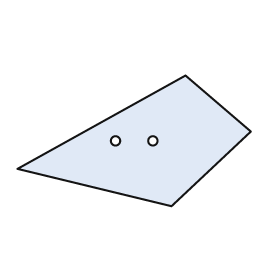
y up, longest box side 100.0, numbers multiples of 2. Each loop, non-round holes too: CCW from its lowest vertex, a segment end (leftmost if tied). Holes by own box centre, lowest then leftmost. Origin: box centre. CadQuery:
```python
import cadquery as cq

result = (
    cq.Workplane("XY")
    .moveTo(16.0, -28.0)
    .lineTo(50.0, 4.0)
    .lineTo(22.0, 28.0)
    .lineTo(-50.0, -12.0)
    .close()
    .moveTo(-8.0, 0.0)
    .circle(2.0)
    .moveTo(8.0, 0.0)
    .circle(2.0)
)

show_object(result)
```